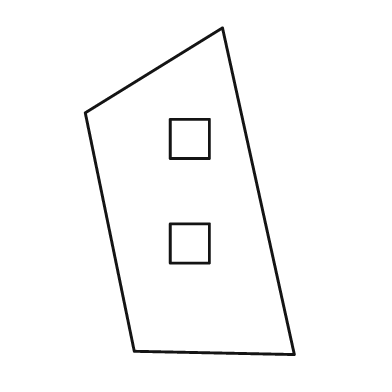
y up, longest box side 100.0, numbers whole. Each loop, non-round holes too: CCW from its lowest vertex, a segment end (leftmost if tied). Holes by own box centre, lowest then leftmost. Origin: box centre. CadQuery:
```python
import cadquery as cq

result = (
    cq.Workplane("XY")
    .moveTo(32.0, -50.0)
    .lineTo(10.0, 50.0)
    .lineTo(-32.0, 24.0)
    .lineTo(-17.0, -49.0)
    .close()
    .moveTo(-6.0, -22.0)
    .lineTo(6.0, -22.0)
    .lineTo(6.0, -10.0)
    .lineTo(-6.0, -10.0)
    .close()
    .moveTo(-6.0, 10.0)
    .lineTo(6.0, 10.0)
    .lineTo(6.0, 22.0)
    .lineTo(-6.0, 22.0)
    .close()
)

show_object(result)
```